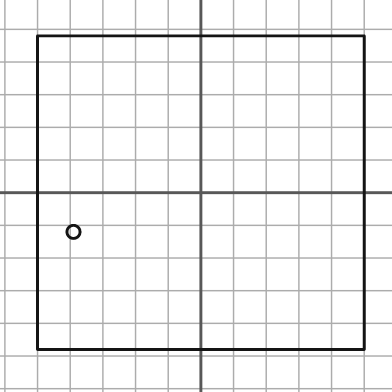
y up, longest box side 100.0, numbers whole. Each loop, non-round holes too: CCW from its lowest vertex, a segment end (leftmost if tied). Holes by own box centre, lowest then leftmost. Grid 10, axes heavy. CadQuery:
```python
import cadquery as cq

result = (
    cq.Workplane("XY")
    .moveTo(-50.0, -48.0)
    .lineTo(50.0, -48.0)
    .lineTo(50.0, 48.0)
    .lineTo(-50.0, 48.0)
    .close()
    .moveTo(-39.0, -12.0)
    .circle(2.0)
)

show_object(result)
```